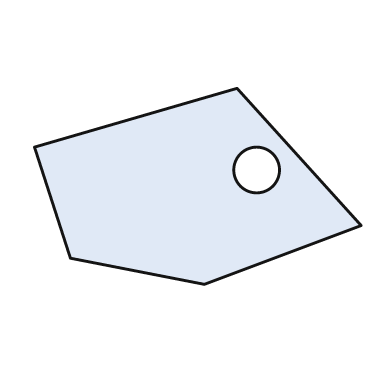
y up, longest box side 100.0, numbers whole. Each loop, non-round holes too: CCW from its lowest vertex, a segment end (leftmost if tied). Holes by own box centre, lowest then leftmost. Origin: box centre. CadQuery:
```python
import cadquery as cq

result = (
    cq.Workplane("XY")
    .moveTo(2.0, -30.0)
    .lineTo(50.0, -12.0)
    .lineTo(12.0, 30.0)
    .lineTo(-50.0, 12.0)
    .lineTo(-39.0, -22.0)
    .close()
    .moveTo(18.0, 5.0)
    .circle(7.0)
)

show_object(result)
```